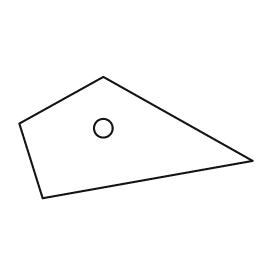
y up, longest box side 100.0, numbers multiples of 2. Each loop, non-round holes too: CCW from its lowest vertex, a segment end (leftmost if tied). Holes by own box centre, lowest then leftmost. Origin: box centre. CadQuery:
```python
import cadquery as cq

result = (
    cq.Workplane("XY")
    .moveTo(-40.0, -26.0)
    .lineTo(50.0, -10.0)
    .lineTo(-14.0, 26.0)
    .lineTo(-50.0, 6.0)
    .close()
    .moveTo(-14.0, 4.0)
    .circle(4.0)
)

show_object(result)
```